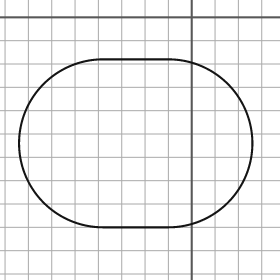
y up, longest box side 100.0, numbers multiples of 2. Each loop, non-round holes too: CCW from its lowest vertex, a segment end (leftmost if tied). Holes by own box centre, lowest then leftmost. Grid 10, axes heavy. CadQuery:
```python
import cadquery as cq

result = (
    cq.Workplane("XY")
    .moveTo(-38.0, -90.0)
    .lineTo(-10.0, -90.0)
    .threePointArc((26.0, -54.0), (-10.0, -18.0))
    .lineTo(-38.0, -18.0)
    .threePointArc((-74.0, -54.0), (-38.0, -90.0))
    .close()
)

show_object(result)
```